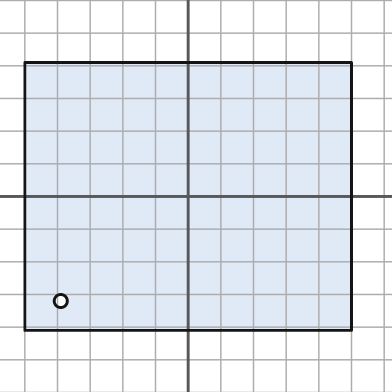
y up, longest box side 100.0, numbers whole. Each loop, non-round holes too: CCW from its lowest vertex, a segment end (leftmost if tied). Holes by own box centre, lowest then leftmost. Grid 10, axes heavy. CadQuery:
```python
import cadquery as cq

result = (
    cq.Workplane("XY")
    .moveTo(-50.0, -41.0)
    .lineTo(50.0, -41.0)
    .lineTo(50.0, 41.0)
    .lineTo(-50.0, 41.0)
    .close()
    .moveTo(-39.0, -32.0)
    .circle(2.0)
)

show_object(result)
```